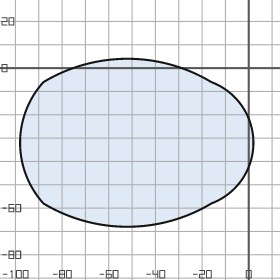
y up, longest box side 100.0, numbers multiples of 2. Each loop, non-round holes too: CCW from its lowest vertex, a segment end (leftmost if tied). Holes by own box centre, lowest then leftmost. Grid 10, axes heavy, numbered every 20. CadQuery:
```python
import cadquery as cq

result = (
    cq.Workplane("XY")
    .moveTo(-88.0, -58.0)
    .threePointArc((-52.0, -68.0), (-16.0, -58.0))
    .threePointArc((2.0, -32.0), (-16.0, -6.0))
    .threePointArc((-52.0, 4.0), (-88.0, -6.0))
    .threePointArc((-98.0, -32.0), (-88.0, -58.0))
    .close()
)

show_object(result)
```